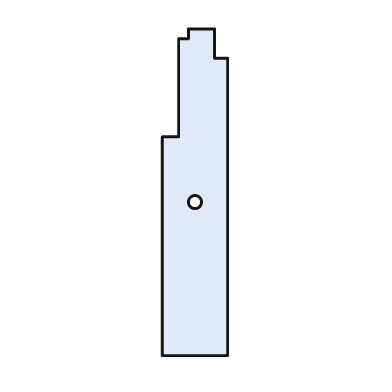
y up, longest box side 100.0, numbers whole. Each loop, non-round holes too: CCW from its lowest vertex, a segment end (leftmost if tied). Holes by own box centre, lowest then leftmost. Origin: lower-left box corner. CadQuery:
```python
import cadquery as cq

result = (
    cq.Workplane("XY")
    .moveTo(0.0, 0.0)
    .lineTo(20.0, 0.0)
    .lineTo(20.0, 91.0)
    .lineTo(16.0, 91.0)
    .lineTo(16.0, 100.0)
    .lineTo(8.0, 100.0)
    .lineTo(8.0, 97.0)
    .lineTo(5.0, 97.0)
    .lineTo(5.0, 67.0)
    .lineTo(0.0, 67.0)
    .close()
    .moveTo(10.0, 47.0)
    .circle(2.0)
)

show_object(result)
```